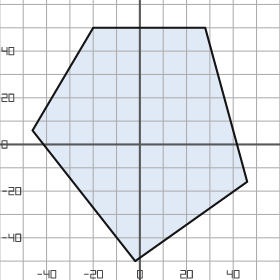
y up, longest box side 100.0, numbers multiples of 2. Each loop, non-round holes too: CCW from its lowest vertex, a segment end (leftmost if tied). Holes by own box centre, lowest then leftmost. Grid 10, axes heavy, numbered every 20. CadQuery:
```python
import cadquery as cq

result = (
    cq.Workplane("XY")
    .moveTo(-2.0, -50.0)
    .lineTo(46.0, -16.0)
    .lineTo(28.0, 50.0)
    .lineTo(-20.0, 50.0)
    .lineTo(-46.0, 6.0)
    .close()
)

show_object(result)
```